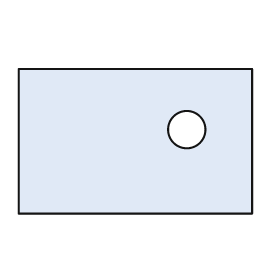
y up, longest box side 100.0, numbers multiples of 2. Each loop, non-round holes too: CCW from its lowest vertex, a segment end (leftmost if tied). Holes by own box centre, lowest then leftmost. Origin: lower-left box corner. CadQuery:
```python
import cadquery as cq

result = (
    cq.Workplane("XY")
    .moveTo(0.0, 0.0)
    .lineTo(100.0, 0.0)
    .lineTo(100.0, 62.0)
    .lineTo(0.0, 62.0)
    .close()
    .moveTo(72.0, 36.0)
    .circle(8.0)
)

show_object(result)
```